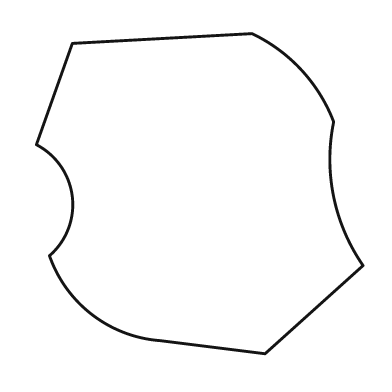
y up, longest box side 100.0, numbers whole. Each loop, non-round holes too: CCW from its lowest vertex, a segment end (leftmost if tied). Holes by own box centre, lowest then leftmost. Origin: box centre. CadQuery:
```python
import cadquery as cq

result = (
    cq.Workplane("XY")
    .moveTo(20.0, -49.0)
    .lineTo(50.0, -22.0)
    .threePointArc((41.0, -1.0), (41.0, 22.0))
    .threePointArc((31.0, 38.0), (16.0, 49.0))
    .lineTo(-39.0, 46.0)
    .lineTo(-50.0, 15.0)
    .threePointArc((-39.0, -1.0), (-46.0, -19.0))
    .threePointArc((-33.0, -37.0), (-12.0, -45.0))
    .close()
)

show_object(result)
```